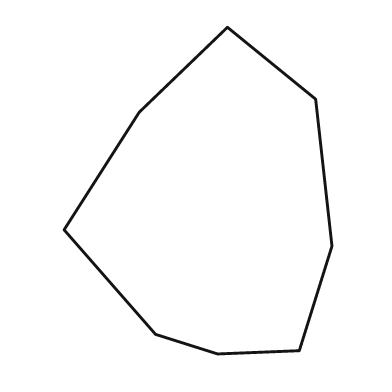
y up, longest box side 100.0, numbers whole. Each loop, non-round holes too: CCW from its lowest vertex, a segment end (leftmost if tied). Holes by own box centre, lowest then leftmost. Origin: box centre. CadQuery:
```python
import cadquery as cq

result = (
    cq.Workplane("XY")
    .moveTo(6.0, -50.0)
    .lineTo(31.0, -49.0)
    .lineTo(41.0, -17.0)
    .lineTo(36.0, 28.0)
    .lineTo(9.0, 50.0)
    .lineTo(-18.0, 24.0)
    .lineTo(-41.0, -12.0)
    .lineTo(-13.0, -44.0)
    .close()
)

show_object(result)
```